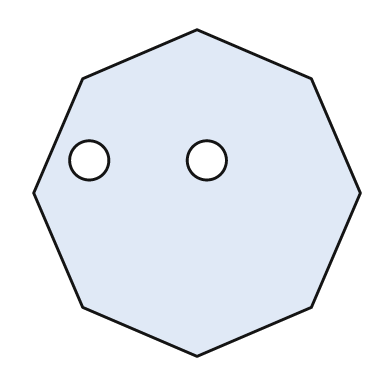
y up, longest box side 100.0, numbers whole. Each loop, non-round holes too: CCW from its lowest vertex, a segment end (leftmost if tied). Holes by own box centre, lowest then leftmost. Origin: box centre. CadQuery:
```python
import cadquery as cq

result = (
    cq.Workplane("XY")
    .moveTo(0.0, -50.0)
    .lineTo(35.0, -35.0)
    .lineTo(50.0, 0.0)
    .lineTo(35.0, 35.0)
    .lineTo(0.0, 50.0)
    .lineTo(-35.0, 35.0)
    .lineTo(-50.0, 0.0)
    .lineTo(-35.0, -35.0)
    .close()
    .moveTo(-33.0, 10.0)
    .circle(6.0)
    .moveTo(3.0, 10.0)
    .circle(6.0)
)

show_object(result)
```